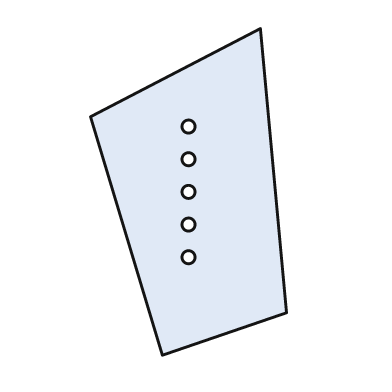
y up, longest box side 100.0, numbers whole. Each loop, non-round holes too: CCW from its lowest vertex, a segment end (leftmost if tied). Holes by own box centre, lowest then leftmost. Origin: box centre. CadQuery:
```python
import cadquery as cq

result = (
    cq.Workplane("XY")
    .moveTo(-8.0, -50.0)
    .lineTo(30.0, -37.0)
    .lineTo(22.0, 50.0)
    .lineTo(-30.0, 23.0)
    .close()
    .moveTo(0.0, -20.0)
    .circle(2.0)
    .moveTo(0.0, -10.0)
    .circle(2.0)
    .moveTo(0.0, 0.0)
    .circle(2.0)
    .moveTo(0.0, 10.0)
    .circle(2.0)
    .moveTo(0.0, 20.0)
    .circle(2.0)
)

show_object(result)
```